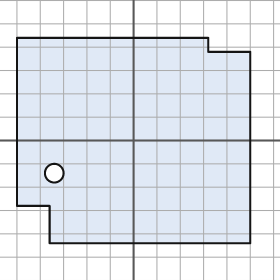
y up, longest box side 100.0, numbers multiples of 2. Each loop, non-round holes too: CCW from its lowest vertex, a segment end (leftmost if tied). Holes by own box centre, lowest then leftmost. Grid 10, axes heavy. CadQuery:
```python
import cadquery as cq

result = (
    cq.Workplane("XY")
    .moveTo(-36.0, -44.0)
    .lineTo(50.0, -44.0)
    .lineTo(50.0, 38.0)
    .lineTo(32.0, 38.0)
    .lineTo(32.0, 44.0)
    .lineTo(-50.0, 44.0)
    .lineTo(-50.0, -28.0)
    .lineTo(-36.0, -28.0)
    .close()
    .moveTo(-34.0, -14.0)
    .circle(4.0)
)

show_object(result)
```